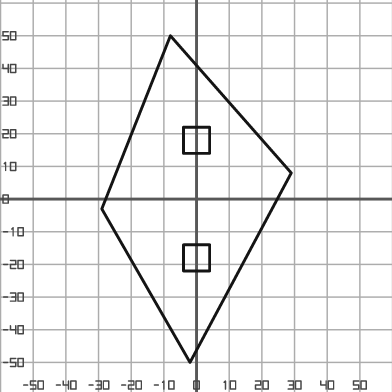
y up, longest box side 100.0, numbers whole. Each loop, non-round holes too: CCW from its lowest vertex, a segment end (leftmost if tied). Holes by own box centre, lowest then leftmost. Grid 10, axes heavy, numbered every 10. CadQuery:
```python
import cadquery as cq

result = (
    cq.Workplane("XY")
    .moveTo(-2.0, -50.0)
    .lineTo(29.0, 8.0)
    .lineTo(-8.0, 50.0)
    .lineTo(-29.0, -3.0)
    .close()
    .moveTo(-4.0, -22.0)
    .lineTo(4.0, -22.0)
    .lineTo(4.0, -14.0)
    .lineTo(-4.0, -14.0)
    .close()
    .moveTo(-4.0, 14.0)
    .lineTo(4.0, 14.0)
    .lineTo(4.0, 22.0)
    .lineTo(-4.0, 22.0)
    .close()
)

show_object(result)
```